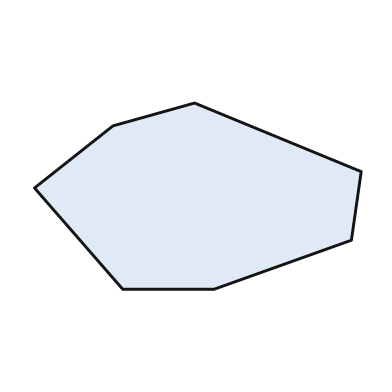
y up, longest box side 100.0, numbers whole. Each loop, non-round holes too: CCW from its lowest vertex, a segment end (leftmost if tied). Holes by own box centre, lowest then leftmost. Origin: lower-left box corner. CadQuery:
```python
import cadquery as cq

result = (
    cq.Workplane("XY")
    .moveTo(27.0, 0.0)
    .lineTo(55.0, 0.0)
    .lineTo(97.0, 15.0)
    .lineTo(100.0, 36.0)
    .lineTo(49.0, 57.0)
    .lineTo(24.0, 50.0)
    .lineTo(0.0, 31.0)
    .close()
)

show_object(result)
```